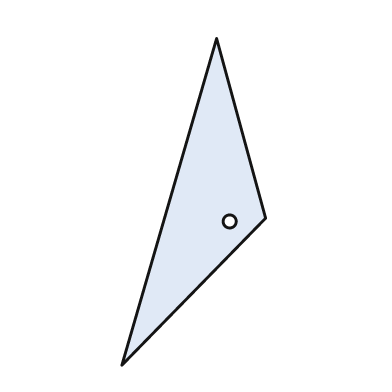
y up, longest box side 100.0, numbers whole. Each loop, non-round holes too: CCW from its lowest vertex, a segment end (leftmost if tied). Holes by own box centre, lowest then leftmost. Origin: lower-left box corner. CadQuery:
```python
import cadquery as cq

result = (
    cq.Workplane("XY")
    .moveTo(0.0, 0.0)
    .lineTo(44.0, 45.0)
    .lineTo(29.0, 100.0)
    .close()
    .moveTo(33.0, 44.0)
    .circle(2.0)
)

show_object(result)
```